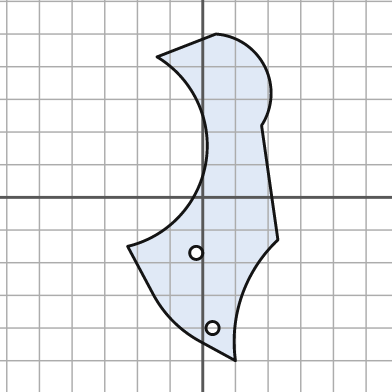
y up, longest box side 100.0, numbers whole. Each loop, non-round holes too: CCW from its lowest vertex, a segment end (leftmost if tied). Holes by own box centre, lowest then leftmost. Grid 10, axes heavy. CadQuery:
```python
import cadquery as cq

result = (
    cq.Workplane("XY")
    .moveTo(10.0, -50.0)
    .threePointArc((12.0, -30.0), (23.0, -13.0))
    .lineTo(18.0, 22.0)
    .threePointArc((19.0, 40.0), (4.0, 50.0))
    .lineTo(-14.0, 43.0)
    .threePointArc((1.0, 11.0), (-23.0, -15.0))
    .lineTo(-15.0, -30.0)
    .threePointArc((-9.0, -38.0), (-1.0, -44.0))
    .close()
    .moveTo(3.0, -40.0)
    .circle(2.0)
    .moveTo(-2.0, -17.0)
    .circle(2.0)
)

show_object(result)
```